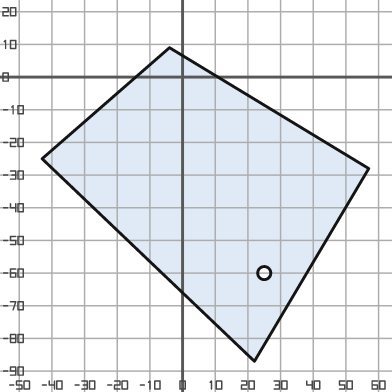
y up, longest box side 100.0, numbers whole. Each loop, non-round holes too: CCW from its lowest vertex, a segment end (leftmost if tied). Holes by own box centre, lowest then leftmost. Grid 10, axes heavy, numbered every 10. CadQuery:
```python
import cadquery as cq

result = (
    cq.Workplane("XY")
    .moveTo(22.0, -87.0)
    .lineTo(57.0, -28.0)
    .lineTo(-4.0, 9.0)
    .lineTo(-43.0, -25.0)
    .close()
    .moveTo(25.0, -60.0)
    .circle(2.0)
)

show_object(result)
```